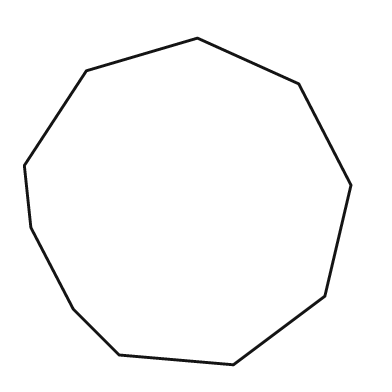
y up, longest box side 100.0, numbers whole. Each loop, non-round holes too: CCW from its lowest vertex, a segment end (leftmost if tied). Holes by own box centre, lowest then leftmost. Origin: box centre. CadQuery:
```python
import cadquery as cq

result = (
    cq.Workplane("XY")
    .moveTo(14.0, -50.0)
    .lineTo(42.0, -29.0)
    .lineTo(50.0, 5.0)
    .lineTo(34.0, 36.0)
    .lineTo(3.0, 50.0)
    .lineTo(-31.0, 40.0)
    .lineTo(-50.0, 11.0)
    .lineTo(-48.0, -8.0)
    .lineTo(-35.0, -33.0)
    .lineTo(-21.0, -47.0)
    .close()
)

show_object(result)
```